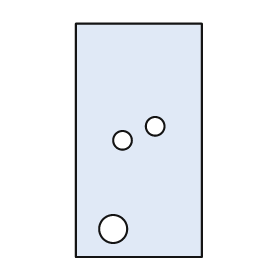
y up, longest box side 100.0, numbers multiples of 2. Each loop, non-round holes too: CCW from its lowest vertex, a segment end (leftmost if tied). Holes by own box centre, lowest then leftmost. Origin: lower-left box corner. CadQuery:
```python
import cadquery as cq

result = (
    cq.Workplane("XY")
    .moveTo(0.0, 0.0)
    .lineTo(54.0, 0.0)
    .lineTo(54.0, 100.0)
    .lineTo(0.0, 100.0)
    .close()
    .moveTo(16.0, 12.0)
    .circle(6.0)
    .moveTo(20.0, 50.0)
    .circle(4.0)
    .moveTo(34.0, 56.0)
    .circle(4.0)
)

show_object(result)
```